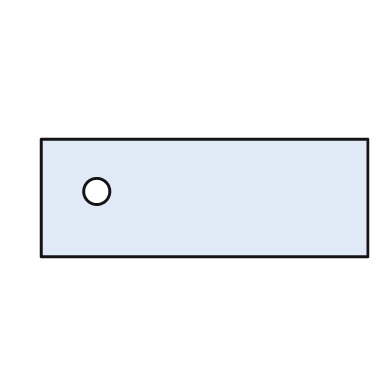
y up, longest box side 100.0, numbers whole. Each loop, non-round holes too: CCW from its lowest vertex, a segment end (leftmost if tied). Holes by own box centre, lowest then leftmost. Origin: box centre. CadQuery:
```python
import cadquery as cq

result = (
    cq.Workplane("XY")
    .moveTo(-50.0, -18.0)
    .lineTo(50.0, -18.0)
    .lineTo(50.0, 18.0)
    .lineTo(-50.0, 18.0)
    .close()
    .moveTo(-33.0, 2.0)
    .circle(4.0)
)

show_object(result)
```